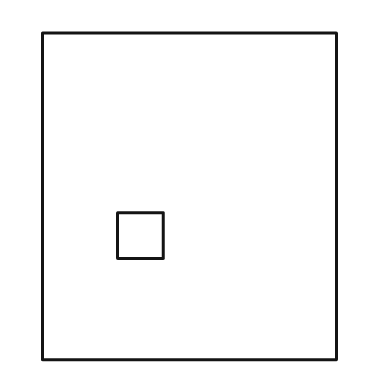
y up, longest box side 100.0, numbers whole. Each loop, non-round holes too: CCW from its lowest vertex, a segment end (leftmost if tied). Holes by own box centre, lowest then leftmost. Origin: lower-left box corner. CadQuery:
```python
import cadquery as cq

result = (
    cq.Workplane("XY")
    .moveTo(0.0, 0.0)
    .lineTo(90.0, 0.0)
    .lineTo(90.0, 100.0)
    .lineTo(0.0, 100.0)
    .close()
    .moveTo(23.0, 31.0)
    .lineTo(37.0, 31.0)
    .lineTo(37.0, 45.0)
    .lineTo(23.0, 45.0)
    .close()
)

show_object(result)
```